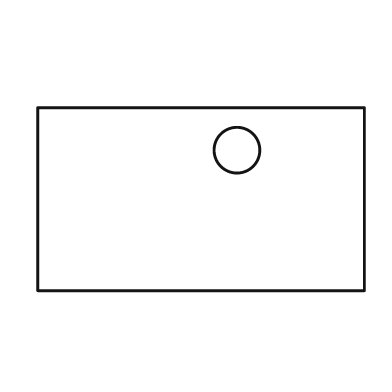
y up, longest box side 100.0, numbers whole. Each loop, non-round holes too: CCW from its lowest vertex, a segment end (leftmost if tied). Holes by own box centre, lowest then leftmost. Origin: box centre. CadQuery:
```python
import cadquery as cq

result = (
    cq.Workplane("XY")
    .moveTo(-50.0, -28.0)
    .lineTo(50.0, -28.0)
    .lineTo(50.0, 28.0)
    .lineTo(-50.0, 28.0)
    .close()
    .moveTo(11.0, 15.0)
    .circle(7.0)
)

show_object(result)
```